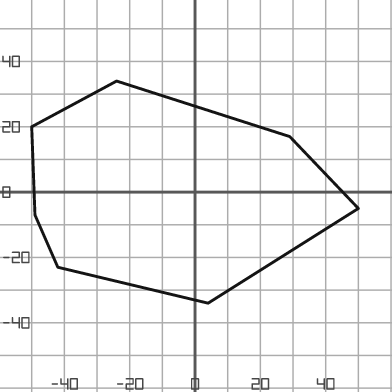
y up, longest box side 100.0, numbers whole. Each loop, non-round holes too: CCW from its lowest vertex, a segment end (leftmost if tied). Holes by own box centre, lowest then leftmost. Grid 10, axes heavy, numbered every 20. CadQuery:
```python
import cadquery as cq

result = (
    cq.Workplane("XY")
    .moveTo(4.0, -34.0)
    .lineTo(50.0, -5.0)
    .lineTo(29.0, 17.0)
    .lineTo(-24.0, 34.0)
    .lineTo(-50.0, 20.0)
    .lineTo(-49.0, -7.0)
    .lineTo(-42.0, -23.0)
    .close()
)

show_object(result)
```